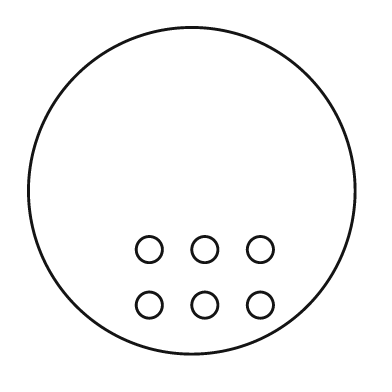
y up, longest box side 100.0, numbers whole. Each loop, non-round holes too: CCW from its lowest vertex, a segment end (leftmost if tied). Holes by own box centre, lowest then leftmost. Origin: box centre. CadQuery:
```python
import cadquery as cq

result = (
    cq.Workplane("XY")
    .moveTo(0.0, 0.0)
    .circle(50.0)
    .moveTo(-13.0, -35.0)
    .circle(4.0)
    .moveTo(4.0, -35.0)
    .circle(4.0)
    .moveTo(21.0, -35.0)
    .circle(4.0)
    .moveTo(-13.0, -18.0)
    .circle(4.0)
    .moveTo(4.0, -18.0)
    .circle(4.0)
    .moveTo(21.0, -18.0)
    .circle(4.0)
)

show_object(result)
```